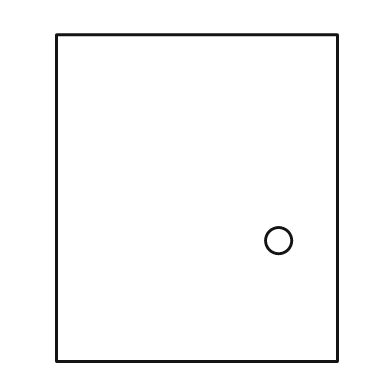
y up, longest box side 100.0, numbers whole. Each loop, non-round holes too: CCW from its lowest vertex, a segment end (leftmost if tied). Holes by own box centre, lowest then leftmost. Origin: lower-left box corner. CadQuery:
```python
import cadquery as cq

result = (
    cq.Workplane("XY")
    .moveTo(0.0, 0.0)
    .lineTo(86.0, 0.0)
    .lineTo(86.0, 100.0)
    .lineTo(0.0, 100.0)
    .close()
    .moveTo(68.0, 37.0)
    .circle(4.0)
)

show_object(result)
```